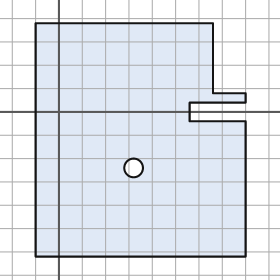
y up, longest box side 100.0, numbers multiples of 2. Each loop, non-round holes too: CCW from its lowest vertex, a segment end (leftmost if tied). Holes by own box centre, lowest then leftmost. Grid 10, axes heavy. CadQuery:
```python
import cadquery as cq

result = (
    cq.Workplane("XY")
    .moveTo(-10.0, -62.0)
    .lineTo(80.0, -62.0)
    .lineTo(80.0, -4.0)
    .lineTo(56.0, -4.0)
    .lineTo(56.0, 4.0)
    .lineTo(80.0, 4.0)
    .lineTo(80.0, 8.0)
    .lineTo(66.0, 8.0)
    .lineTo(66.0, 38.0)
    .lineTo(-10.0, 38.0)
    .close()
    .moveTo(32.0, -24.0)
    .circle(4.0)
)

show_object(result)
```